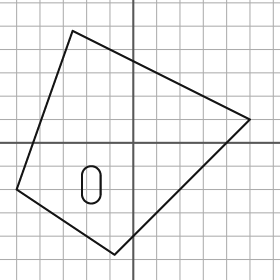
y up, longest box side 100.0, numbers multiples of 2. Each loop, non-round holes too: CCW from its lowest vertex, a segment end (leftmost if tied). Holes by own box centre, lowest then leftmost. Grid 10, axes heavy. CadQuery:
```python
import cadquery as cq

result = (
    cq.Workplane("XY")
    .moveTo(-8.0, -48.0)
    .lineTo(50.0, 10.0)
    .lineTo(-26.0, 48.0)
    .lineTo(-50.0, -20.0)
    .close()
    .moveTo(-22.0, -22.0)
    .threePointArc((-18.0, -26.0), (-14.0, -22.0))
    .lineTo(-14.0, -14.0)
    .threePointArc((-18.0, -10.0), (-22.0, -14.0))
    .close()
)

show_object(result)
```